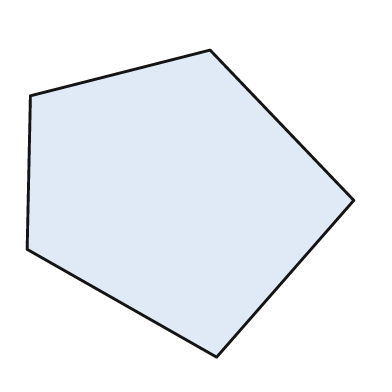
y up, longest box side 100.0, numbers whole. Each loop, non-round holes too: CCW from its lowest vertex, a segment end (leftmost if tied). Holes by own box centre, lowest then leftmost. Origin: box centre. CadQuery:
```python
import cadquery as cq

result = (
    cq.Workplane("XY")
    .moveTo(8.0, -47.0)
    .lineTo(50.0, 1.0)
    .lineTo(6.0, 47.0)
    .lineTo(-49.0, 33.0)
    .lineTo(-50.0, -14.0)
    .close()
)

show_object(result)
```